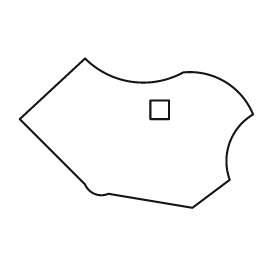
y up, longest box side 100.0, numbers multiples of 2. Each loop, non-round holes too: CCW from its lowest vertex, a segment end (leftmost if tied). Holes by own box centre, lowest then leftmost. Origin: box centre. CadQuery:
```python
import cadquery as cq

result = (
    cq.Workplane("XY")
    .moveTo(24.0, -32.0)
    .lineTo(40.0, -20.0)
    .threePointArc((40.0, -4.0), (50.0, 8.0))
    .threePointArc((38.0, 22.0), (20.0, 26.0))
    .threePointArc((-2.0, 22.0), (-22.0, 32.0))
    .lineTo(-50.0, 6.0)
    .lineTo(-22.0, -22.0)
    .threePointArc((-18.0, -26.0), (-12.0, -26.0))
    .close()
    .moveTo(6.0, 6.0)
    .lineTo(14.0, 6.0)
    .lineTo(14.0, 14.0)
    .lineTo(6.0, 14.0)
    .close()
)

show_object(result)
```